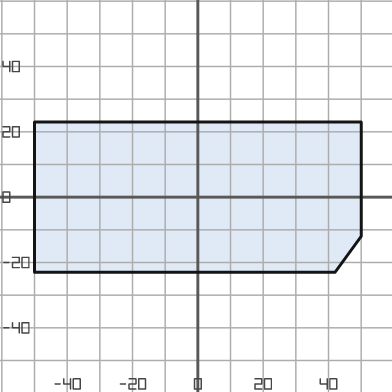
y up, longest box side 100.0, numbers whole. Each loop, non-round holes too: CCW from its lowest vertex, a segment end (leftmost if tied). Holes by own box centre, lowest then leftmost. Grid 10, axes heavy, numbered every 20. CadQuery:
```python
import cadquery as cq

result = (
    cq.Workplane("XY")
    .moveTo(-50.0, -23.0)
    .lineTo(42.0, -23.0)
    .lineTo(50.0, -12.0)
    .lineTo(50.0, 23.0)
    .lineTo(-50.0, 23.0)
    .close()
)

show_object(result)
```